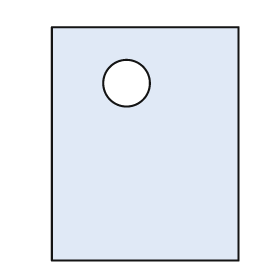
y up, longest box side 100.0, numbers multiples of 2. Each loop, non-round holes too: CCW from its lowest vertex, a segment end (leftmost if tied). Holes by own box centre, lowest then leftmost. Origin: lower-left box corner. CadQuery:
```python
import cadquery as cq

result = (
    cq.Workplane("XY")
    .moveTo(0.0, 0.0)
    .lineTo(80.0, 0.0)
    .lineTo(80.0, 100.0)
    .lineTo(0.0, 100.0)
    .close()
    .moveTo(32.0, 76.0)
    .circle(10.0)
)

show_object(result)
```